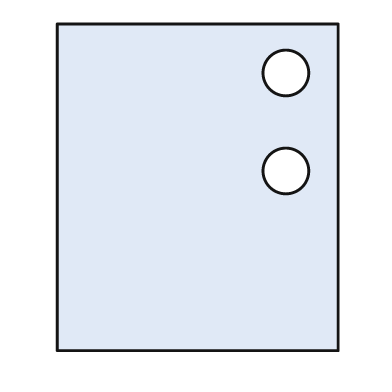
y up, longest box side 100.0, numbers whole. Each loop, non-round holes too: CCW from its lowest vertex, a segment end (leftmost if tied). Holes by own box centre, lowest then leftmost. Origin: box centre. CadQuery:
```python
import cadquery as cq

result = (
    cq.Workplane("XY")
    .moveTo(-43.0, -50.0)
    .lineTo(43.0, -50.0)
    .lineTo(43.0, 50.0)
    .lineTo(-43.0, 50.0)
    .close()
    .moveTo(27.0, 5.0)
    .circle(7.0)
    .moveTo(27.0, 35.0)
    .circle(7.0)
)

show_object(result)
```